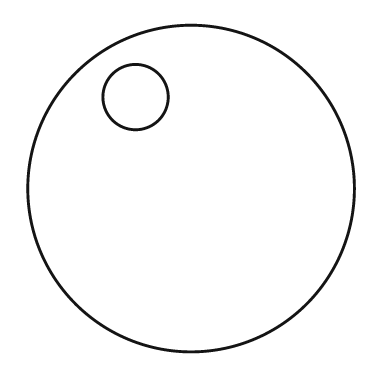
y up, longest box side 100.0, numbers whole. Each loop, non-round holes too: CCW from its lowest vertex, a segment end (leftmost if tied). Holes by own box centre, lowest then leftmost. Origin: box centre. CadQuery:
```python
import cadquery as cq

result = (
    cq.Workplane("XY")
    .moveTo(0.0, 0.0)
    .circle(50.0)
    .moveTo(-17.0, 28.0)
    .circle(10.0)
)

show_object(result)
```